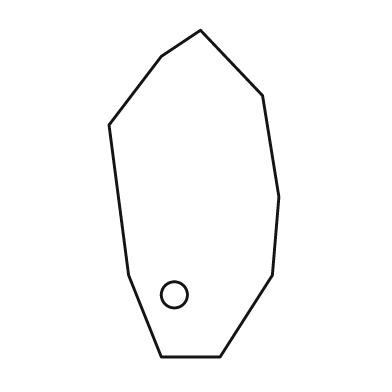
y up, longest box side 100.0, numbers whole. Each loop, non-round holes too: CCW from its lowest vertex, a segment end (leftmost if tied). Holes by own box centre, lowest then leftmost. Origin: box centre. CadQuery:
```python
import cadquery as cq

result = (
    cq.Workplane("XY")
    .moveTo(-10.0, -50.0)
    .lineTo(8.0, -50.0)
    .lineTo(24.0, -25.0)
    .lineTo(26.0, -1.0)
    .lineTo(21.0, 30.0)
    .lineTo(2.0, 50.0)
    .lineTo(-10.0, 42.0)
    .lineTo(-26.0, 21.0)
    .lineTo(-20.0, -25.0)
    .close()
    .moveTo(-6.0, -31.0)
    .circle(4.0)
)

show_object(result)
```